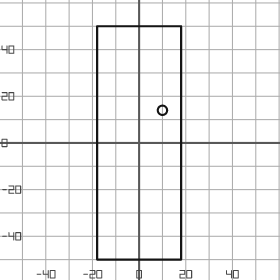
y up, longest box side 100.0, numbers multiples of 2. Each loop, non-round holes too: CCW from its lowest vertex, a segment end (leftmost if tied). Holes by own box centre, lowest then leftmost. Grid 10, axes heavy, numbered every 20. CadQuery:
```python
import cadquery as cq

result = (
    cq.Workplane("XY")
    .moveTo(-18.0, -50.0)
    .lineTo(18.0, -50.0)
    .lineTo(18.0, 50.0)
    .lineTo(-18.0, 50.0)
    .close()
    .moveTo(10.0, 14.0)
    .circle(2.0)
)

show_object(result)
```